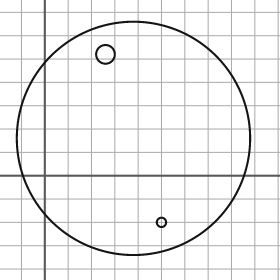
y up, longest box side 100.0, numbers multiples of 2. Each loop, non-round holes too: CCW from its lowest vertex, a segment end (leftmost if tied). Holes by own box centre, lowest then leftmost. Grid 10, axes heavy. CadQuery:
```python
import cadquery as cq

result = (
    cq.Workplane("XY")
    .moveTo(38.0, 16.0)
    .circle(50.0)
    .moveTo(50.0, -20.0)
    .circle(2.0)
    .moveTo(26.0, 52.0)
    .circle(4.0)
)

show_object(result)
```